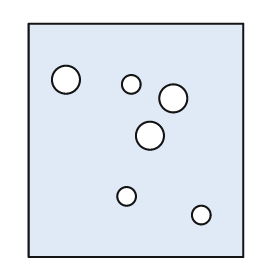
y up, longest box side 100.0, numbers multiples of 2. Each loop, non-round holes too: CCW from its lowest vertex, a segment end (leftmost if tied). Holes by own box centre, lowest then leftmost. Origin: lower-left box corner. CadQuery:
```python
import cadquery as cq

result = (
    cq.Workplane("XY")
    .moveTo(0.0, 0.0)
    .lineTo(92.0, 0.0)
    .lineTo(92.0, 100.0)
    .lineTo(0.0, 100.0)
    .close()
    .moveTo(74.0, 18.0)
    .circle(4.0)
    .moveTo(42.0, 26.0)
    .circle(4.0)
    .moveTo(52.0, 52.0)
    .circle(6.0)
    .moveTo(62.0, 68.0)
    .circle(6.0)
    .moveTo(44.0, 74.0)
    .circle(4.0)
    .moveTo(16.0, 76.0)
    .circle(6.0)
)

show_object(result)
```